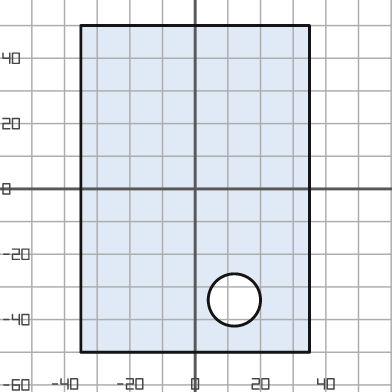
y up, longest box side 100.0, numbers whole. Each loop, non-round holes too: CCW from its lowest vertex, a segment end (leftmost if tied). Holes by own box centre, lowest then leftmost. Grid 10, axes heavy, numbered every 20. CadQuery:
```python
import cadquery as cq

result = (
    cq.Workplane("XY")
    .moveTo(-35.0, -50.0)
    .lineTo(35.0, -50.0)
    .lineTo(35.0, 50.0)
    .lineTo(-35.0, 50.0)
    .close()
    .moveTo(12.0, -34.0)
    .circle(8.0)
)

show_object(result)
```